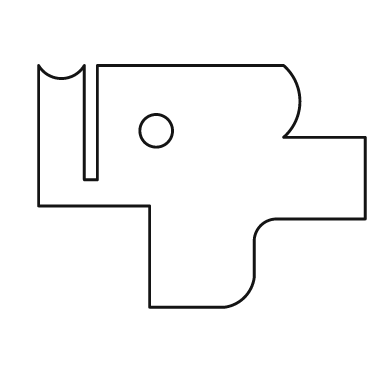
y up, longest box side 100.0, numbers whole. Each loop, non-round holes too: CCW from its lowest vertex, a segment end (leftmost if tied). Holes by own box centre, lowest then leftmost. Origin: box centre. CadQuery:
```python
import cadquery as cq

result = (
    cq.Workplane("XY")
    .moveTo(-16.0, -37.0)
    .lineTo(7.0, -37.0)
    .threePointArc((13.0, -34.0), (16.0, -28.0))
    .lineTo(16.0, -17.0)
    .threePointArc((18.0, -12.0), (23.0, -10.0))
    .lineTo(50.0, -10.0)
    .lineTo(50.0, 15.0)
    .lineTo(25.0, 15.0)
    .threePointArc((30.0, 26.0), (25.0, 37.0))
    .lineTo(-32.0, 37.0)
    .lineTo(-32.0, 2.0)
    .lineTo(-36.0, 2.0)
    .lineTo(-36.0, 37.0)
    .threePointArc((-43.0, 33.0), (-50.0, 37.0))
    .lineTo(-50.0, -6.0)
    .lineTo(-16.0, -6.0)
    .close()
    .moveTo(-14.0, 17.0)
    .circle(5.0)
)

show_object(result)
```